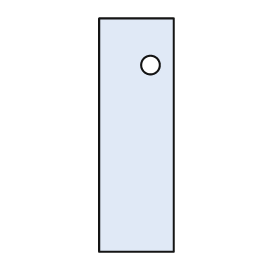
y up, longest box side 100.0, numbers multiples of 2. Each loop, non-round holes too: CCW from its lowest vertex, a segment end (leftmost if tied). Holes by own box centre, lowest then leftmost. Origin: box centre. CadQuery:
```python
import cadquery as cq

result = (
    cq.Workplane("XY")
    .moveTo(-16.0, -50.0)
    .lineTo(16.0, -50.0)
    .lineTo(16.0, 50.0)
    .lineTo(-16.0, 50.0)
    .close()
    .moveTo(6.0, 30.0)
    .circle(4.0)
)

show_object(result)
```